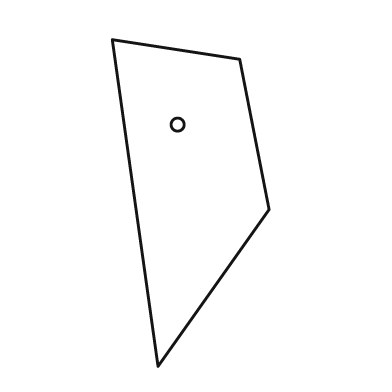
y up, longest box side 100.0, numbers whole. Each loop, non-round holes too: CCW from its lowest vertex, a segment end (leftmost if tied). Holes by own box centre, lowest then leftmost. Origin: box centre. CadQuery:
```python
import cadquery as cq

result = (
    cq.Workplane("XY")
    .moveTo(-10.0, -50.0)
    .lineTo(24.0, -2.0)
    .lineTo(15.0, 44.0)
    .lineTo(-24.0, 50.0)
    .close()
    .moveTo(-4.0, 24.0)
    .circle(2.0)
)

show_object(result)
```